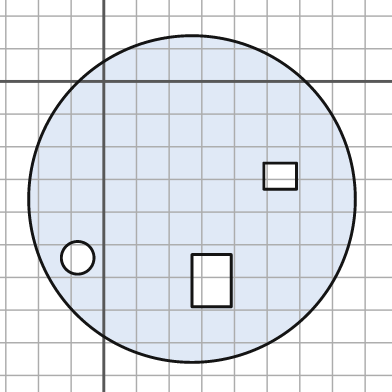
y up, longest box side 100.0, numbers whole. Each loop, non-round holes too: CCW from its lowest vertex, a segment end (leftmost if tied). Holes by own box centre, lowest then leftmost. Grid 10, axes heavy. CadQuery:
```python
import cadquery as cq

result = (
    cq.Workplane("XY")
    .moveTo(27.0, -36.0)
    .circle(50.0)
    .moveTo(27.0, -69.0)
    .lineTo(39.0, -69.0)
    .lineTo(39.0, -53.0)
    .lineTo(27.0, -53.0)
    .close()
    .moveTo(-8.0, -54.0)
    .circle(5.0)
    .moveTo(49.0, -33.0)
    .lineTo(59.0, -33.0)
    .lineTo(59.0, -25.0)
    .lineTo(49.0, -25.0)
    .close()
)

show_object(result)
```